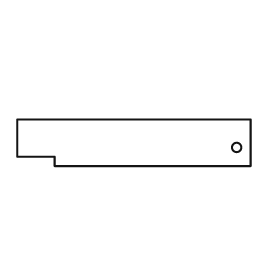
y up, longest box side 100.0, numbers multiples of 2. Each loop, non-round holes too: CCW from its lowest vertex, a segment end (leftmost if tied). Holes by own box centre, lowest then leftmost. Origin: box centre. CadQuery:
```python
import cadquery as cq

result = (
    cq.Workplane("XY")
    .moveTo(-34.0, -10.0)
    .lineTo(50.0, -10.0)
    .lineTo(50.0, 10.0)
    .lineTo(-50.0, 10.0)
    .lineTo(-50.0, -6.0)
    .lineTo(-34.0, -6.0)
    .close()
    .moveTo(44.0, -2.0)
    .circle(2.0)
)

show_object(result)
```